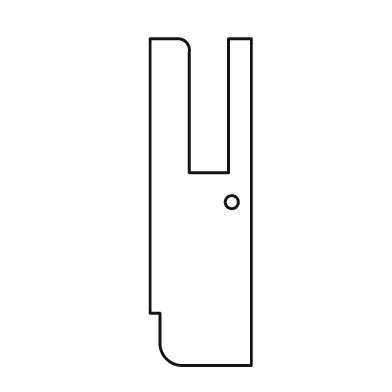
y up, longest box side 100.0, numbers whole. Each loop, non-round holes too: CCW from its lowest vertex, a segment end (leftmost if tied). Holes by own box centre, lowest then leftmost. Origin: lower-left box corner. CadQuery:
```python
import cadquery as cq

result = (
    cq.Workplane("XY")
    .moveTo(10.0, 0.0)
    .lineTo(31.0, 0.0)
    .lineTo(31.0, 100.0)
    .lineTo(24.0, 100.0)
    .lineTo(24.0, 59.0)
    .lineTo(12.0, 59.0)
    .lineTo(12.0, 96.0)
    .threePointArc((11.0, 99.0), (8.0, 100.0))
    .lineTo(0.0, 100.0)
    .lineTo(0.0, 16.0)
    .lineTo(3.0, 16.0)
    .lineTo(3.0, 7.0)
    .threePointArc((5.0, 2.0), (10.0, 0.0))
    .close()
    .moveTo(25.0, 50.0)
    .circle(2.0)
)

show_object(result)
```